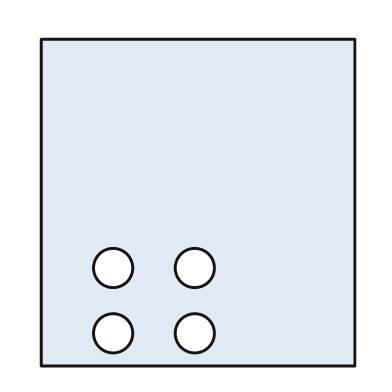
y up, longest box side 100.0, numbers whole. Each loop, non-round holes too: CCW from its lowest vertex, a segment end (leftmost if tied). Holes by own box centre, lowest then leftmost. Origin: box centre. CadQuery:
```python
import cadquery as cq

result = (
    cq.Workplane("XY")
    .moveTo(-48.0, -50.0)
    .lineTo(48.0, -50.0)
    .lineTo(48.0, 50.0)
    .lineTo(-48.0, 50.0)
    .close()
    .moveTo(-26.0, -40.0)
    .circle(6.0)
    .moveTo(-1.0, -40.0)
    .circle(6.0)
    .moveTo(-26.0, -20.0)
    .circle(6.0)
    .moveTo(-1.0, -20.0)
    .circle(6.0)
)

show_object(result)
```